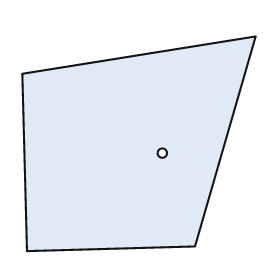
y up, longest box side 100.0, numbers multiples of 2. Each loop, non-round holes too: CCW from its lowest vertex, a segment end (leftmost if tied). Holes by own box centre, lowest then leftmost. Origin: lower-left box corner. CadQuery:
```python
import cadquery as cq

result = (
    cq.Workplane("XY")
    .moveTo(2.0, 0.0)
    .lineTo(74.0, 2.0)
    .lineTo(100.0, 92.0)
    .lineTo(0.0, 76.0)
    .close()
    .moveTo(60.0, 42.0)
    .circle(2.0)
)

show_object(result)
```